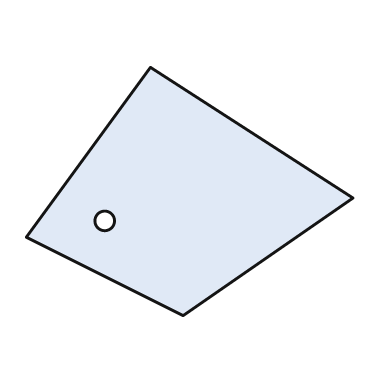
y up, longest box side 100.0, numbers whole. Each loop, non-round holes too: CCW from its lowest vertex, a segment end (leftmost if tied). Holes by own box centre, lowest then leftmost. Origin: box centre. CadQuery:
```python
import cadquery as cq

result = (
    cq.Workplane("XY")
    .moveTo(-2.0, -38.0)
    .lineTo(50.0, -2.0)
    .lineTo(-12.0, 38.0)
    .lineTo(-50.0, -14.0)
    .close()
    .moveTo(-26.0, -9.0)
    .circle(3.0)
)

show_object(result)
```